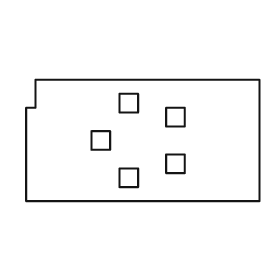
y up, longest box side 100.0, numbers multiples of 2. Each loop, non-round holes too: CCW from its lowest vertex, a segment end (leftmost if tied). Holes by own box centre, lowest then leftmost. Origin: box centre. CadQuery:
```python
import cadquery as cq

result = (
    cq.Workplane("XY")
    .moveTo(-50.0, -26.0)
    .lineTo(50.0, -26.0)
    .lineTo(50.0, 26.0)
    .lineTo(-46.0, 26.0)
    .lineTo(-46.0, 14.0)
    .lineTo(-50.0, 14.0)
    .close()
    .moveTo(-10.0, -20.0)
    .lineTo(-2.0, -20.0)
    .lineTo(-2.0, -12.0)
    .lineTo(-10.0, -12.0)
    .close()
    .moveTo(10.0, -14.0)
    .lineTo(18.0, -14.0)
    .lineTo(18.0, -6.0)
    .lineTo(10.0, -6.0)
    .close()
    .moveTo(-22.0, -4.0)
    .lineTo(-14.0, -4.0)
    .lineTo(-14.0, 4.0)
    .lineTo(-22.0, 4.0)
    .close()
    .moveTo(10.0, 6.0)
    .lineTo(18.0, 6.0)
    .lineTo(18.0, 14.0)
    .lineTo(10.0, 14.0)
    .close()
    .moveTo(-10.0, 12.0)
    .lineTo(-2.0, 12.0)
    .lineTo(-2.0, 20.0)
    .lineTo(-10.0, 20.0)
    .close()
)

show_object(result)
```